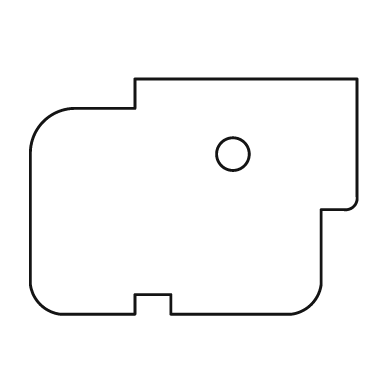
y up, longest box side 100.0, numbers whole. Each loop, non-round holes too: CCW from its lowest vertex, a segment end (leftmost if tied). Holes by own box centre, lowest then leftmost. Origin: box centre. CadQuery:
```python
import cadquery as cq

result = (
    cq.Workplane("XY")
    .moveTo(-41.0, -36.0)
    .lineTo(-18.0, -36.0)
    .lineTo(-18.0, -30.0)
    .lineTo(-7.0, -30.0)
    .lineTo(-7.0, -36.0)
    .lineTo(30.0, -36.0)
    .threePointArc((36.0, -33.0), (39.0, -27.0))
    .lineTo(39.0, -4.0)
    .lineTo(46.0, -4.0)
    .threePointArc((49.0, -3.0), (50.0, 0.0))
    .lineTo(50.0, 36.0)
    .lineTo(-18.0, 36.0)
    .lineTo(-18.0, 27.0)
    .lineTo(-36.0, 27.0)
    .threePointArc((-46.0, 23.0), (-50.0, 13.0))
    .lineTo(-50.0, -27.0)
    .threePointArc((-47.0, -33.0), (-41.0, -36.0))
    .close()
    .moveTo(12.0, 13.0)
    .circle(5.0)
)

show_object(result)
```